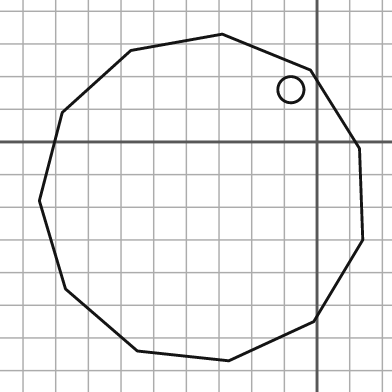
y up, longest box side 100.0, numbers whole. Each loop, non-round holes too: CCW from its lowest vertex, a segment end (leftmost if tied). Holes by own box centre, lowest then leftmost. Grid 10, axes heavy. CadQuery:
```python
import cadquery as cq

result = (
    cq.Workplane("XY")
    .moveTo(-27.0, -67.0)
    .lineTo(-1.0, -55.0)
    .lineTo(14.0, -30.0)
    .lineTo(13.0, -2.0)
    .lineTo(-2.0, 22.0)
    .lineTo(-29.0, 33.0)
    .lineTo(-57.0, 28.0)
    .lineTo(-78.0, 9.0)
    .lineTo(-85.0, -18.0)
    .lineTo(-77.0, -45.0)
    .lineTo(-55.0, -64.0)
    .close()
    .moveTo(-8.0, 16.0)
    .circle(4.0)
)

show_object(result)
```